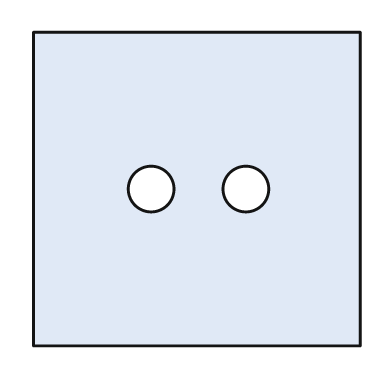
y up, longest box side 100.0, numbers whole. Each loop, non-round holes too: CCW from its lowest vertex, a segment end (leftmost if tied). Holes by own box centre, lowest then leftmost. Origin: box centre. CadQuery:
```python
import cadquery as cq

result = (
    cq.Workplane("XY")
    .moveTo(-50.0, -48.0)
    .lineTo(50.0, -48.0)
    .lineTo(50.0, 48.0)
    .lineTo(-50.0, 48.0)
    .close()
    .moveTo(-14.0, 0.0)
    .circle(7.0)
    .moveTo(15.0, 0.0)
    .circle(7.0)
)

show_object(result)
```